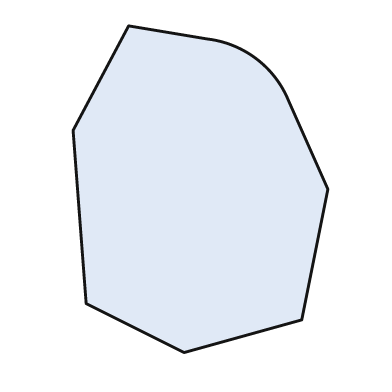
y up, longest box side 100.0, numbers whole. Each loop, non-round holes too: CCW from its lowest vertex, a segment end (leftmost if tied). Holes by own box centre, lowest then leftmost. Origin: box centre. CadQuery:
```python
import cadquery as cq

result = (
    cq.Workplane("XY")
    .moveTo(-5.0, -50.0)
    .lineTo(31.0, -40.0)
    .lineTo(39.0, 0.0)
    .lineTo(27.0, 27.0)
    .threePointArc((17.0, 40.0), (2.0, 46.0))
    .lineTo(-22.0, 50.0)
    .lineTo(-39.0, 18.0)
    .lineTo(-35.0, -35.0)
    .close()
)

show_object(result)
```